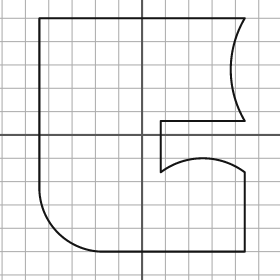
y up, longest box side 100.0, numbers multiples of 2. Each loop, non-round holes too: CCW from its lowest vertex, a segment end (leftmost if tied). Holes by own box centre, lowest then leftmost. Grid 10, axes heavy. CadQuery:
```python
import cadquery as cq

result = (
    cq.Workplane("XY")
    .moveTo(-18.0, -50.0)
    .lineTo(44.0, -50.0)
    .lineTo(44.0, -16.0)
    .threePointArc((26.0, -10.0), (8.0, -16.0))
    .lineTo(8.0, 6.0)
    .lineTo(44.0, 6.0)
    .threePointArc((38.0, 28.0), (44.0, 50.0))
    .lineTo(-44.0, 50.0)
    .lineTo(-44.0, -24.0)
    .threePointArc((-36.0, -42.0), (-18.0, -50.0))
    .close()
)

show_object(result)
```